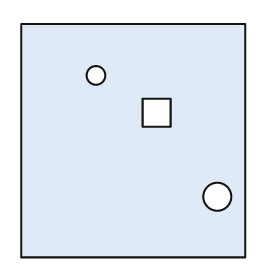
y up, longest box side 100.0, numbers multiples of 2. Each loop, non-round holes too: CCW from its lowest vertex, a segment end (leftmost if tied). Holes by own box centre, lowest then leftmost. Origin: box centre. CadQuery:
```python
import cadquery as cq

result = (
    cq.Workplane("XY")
    .moveTo(-48.0, -50.0)
    .lineTo(48.0, -50.0)
    .lineTo(48.0, 50.0)
    .lineTo(-48.0, 50.0)
    .close()
    .moveTo(36.0, -24.0)
    .circle(6.0)
    .moveTo(4.0, 6.0)
    .lineTo(16.0, 6.0)
    .lineTo(16.0, 18.0)
    .lineTo(4.0, 18.0)
    .close()
    .moveTo(-16.0, 28.0)
    .circle(4.0)
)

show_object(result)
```